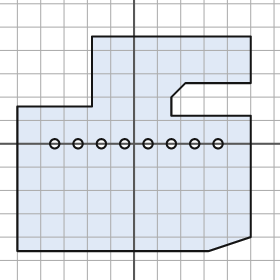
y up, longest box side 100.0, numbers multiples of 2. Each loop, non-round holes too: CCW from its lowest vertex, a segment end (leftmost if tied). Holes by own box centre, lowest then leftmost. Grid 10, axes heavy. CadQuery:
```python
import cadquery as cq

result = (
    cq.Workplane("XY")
    .moveTo(-50.0, -46.0)
    .lineTo(32.0, -46.0)
    .lineTo(50.0, -40.0)
    .lineTo(50.0, 12.0)
    .lineTo(16.0, 12.0)
    .lineTo(16.0, 20.0)
    .lineTo(22.0, 26.0)
    .lineTo(50.0, 26.0)
    .lineTo(50.0, 46.0)
    .lineTo(-18.0, 46.0)
    .lineTo(-18.0, 16.0)
    .lineTo(-50.0, 16.0)
    .close()
    .moveTo(-34.0, 0.0)
    .circle(2.0)
    .moveTo(-24.0, 0.0)
    .circle(2.0)
    .moveTo(-14.0, 0.0)
    .circle(2.0)
    .moveTo(-4.0, 0.0)
    .circle(2.0)
    .moveTo(6.0, 0.0)
    .circle(2.0)
    .moveTo(16.0, 0.0)
    .circle(2.0)
    .moveTo(26.0, 0.0)
    .circle(2.0)
    .moveTo(36.0, 0.0)
    .circle(2.0)
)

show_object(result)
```